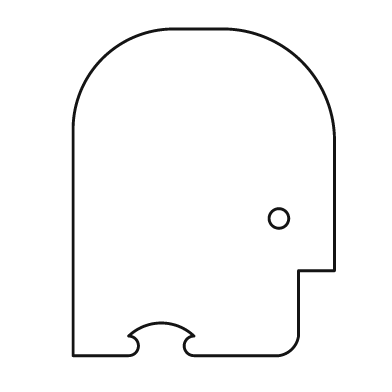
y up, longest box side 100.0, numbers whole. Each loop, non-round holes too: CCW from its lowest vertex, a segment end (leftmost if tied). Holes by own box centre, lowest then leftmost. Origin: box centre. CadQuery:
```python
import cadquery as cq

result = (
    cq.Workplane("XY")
    .moveTo(-40.0, -50.0)
    .lineTo(-23.0, -50.0)
    .threePointArc((-20.0, -47.0), (-23.0, -44.0))
    .threePointArc((-13.0, -40.0), (-3.0, -44.0))
    .threePointArc((-6.0, -47.0), (-3.0, -50.0))
    .lineTo(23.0, -50.0)
    .threePointArc((27.0, -48.0), (29.0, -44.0))
    .lineTo(29.0, -24.0)
    .lineTo(40.0, -24.0)
    .lineTo(40.0, 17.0)
    .threePointArc((30.0, 40.0), (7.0, 50.0))
    .lineTo(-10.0, 50.0)
    .threePointArc((-31.0, 41.0), (-40.0, 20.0))
    .close()
    .moveTo(23.0, -8.0)
    .circle(3.0)
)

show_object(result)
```